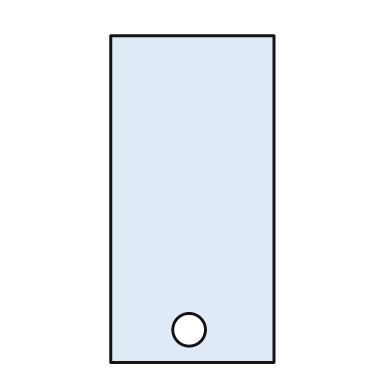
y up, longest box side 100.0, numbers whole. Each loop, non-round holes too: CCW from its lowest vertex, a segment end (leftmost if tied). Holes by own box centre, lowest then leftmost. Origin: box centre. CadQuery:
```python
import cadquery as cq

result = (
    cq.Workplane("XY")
    .moveTo(-25.0, -50.0)
    .lineTo(25.0, -50.0)
    .lineTo(25.0, 50.0)
    .lineTo(-25.0, 50.0)
    .close()
    .moveTo(-1.0, -40.0)
    .circle(5.0)
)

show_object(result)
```